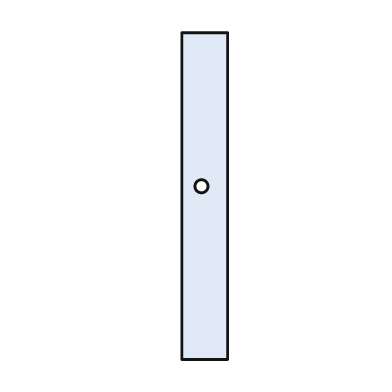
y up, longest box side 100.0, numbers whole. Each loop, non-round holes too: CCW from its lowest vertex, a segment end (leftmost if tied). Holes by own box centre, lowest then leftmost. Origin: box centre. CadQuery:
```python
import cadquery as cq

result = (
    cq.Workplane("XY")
    .moveTo(-7.0, -50.0)
    .lineTo(7.0, -50.0)
    .lineTo(7.0, 50.0)
    .lineTo(-7.0, 50.0)
    .close()
    .moveTo(-1.0, 3.0)
    .circle(2.0)
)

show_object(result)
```